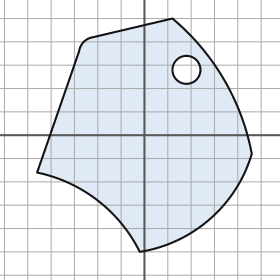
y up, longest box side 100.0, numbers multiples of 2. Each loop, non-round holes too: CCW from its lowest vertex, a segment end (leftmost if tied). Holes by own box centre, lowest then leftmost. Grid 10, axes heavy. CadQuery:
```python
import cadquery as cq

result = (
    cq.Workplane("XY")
    .moveTo(-2.0, -50.0)
    .threePointArc((28.0, -36.0), (46.0, -8.0))
    .threePointArc((34.0, 24.0), (12.0, 50.0))
    .lineTo(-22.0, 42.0)
    .threePointArc((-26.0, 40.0), (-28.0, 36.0))
    .lineTo(-46.0, -16.0)
    .threePointArc((-20.0, -28.0), (-2.0, -50.0))
    .close()
    .moveTo(18.0, 28.0)
    .circle(6.0)
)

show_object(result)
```